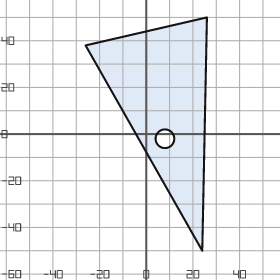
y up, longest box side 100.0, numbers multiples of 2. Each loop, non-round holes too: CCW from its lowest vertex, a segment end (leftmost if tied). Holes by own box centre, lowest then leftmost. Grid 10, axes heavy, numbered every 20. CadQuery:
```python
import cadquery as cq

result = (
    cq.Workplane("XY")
    .moveTo(24.0, -50.0)
    .lineTo(26.0, 50.0)
    .lineTo(-26.0, 38.0)
    .close()
    .moveTo(8.0, -2.0)
    .circle(4.0)
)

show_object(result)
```